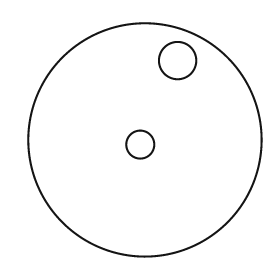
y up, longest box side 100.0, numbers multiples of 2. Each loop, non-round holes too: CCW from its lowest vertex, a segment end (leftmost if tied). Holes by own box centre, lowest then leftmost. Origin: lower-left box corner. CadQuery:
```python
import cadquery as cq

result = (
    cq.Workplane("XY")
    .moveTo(50.0, 50.0)
    .circle(50.0)
    .moveTo(48.0, 48.0)
    .circle(6.0)
    .moveTo(64.0, 84.0)
    .circle(8.0)
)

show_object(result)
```